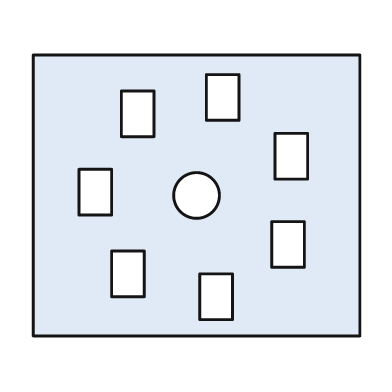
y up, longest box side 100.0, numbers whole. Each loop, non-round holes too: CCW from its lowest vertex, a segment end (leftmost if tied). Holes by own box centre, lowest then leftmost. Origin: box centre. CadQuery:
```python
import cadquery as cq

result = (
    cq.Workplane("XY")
    .moveTo(-50.0, -43.0)
    .lineTo(50.0, -43.0)
    .lineTo(50.0, 43.0)
    .lineTo(-50.0, 43.0)
    .close()
    .moveTo(1.0, -38.0)
    .lineTo(11.0, -38.0)
    .lineTo(11.0, -24.0)
    .lineTo(1.0, -24.0)
    .close()
    .moveTo(-26.0, -31.0)
    .lineTo(-16.0, -31.0)
    .lineTo(-16.0, -17.0)
    .lineTo(-26.0, -17.0)
    .close()
    .moveTo(23.0, -22.0)
    .lineTo(33.0, -22.0)
    .lineTo(33.0, -8.0)
    .lineTo(23.0, -8.0)
    .close()
    .moveTo(0.0, 0.0)
    .circle(7.0)
    .moveTo(-36.0, -6.0)
    .lineTo(-26.0, -6.0)
    .lineTo(-26.0, 8.0)
    .lineTo(-36.0, 8.0)
    .close()
    .moveTo(24.0, 5.0)
    .lineTo(34.0, 5.0)
    .lineTo(34.0, 19.0)
    .lineTo(24.0, 19.0)
    .close()
    .moveTo(-23.0, 18.0)
    .lineTo(-13.0, 18.0)
    .lineTo(-13.0, 32.0)
    .lineTo(-23.0, 32.0)
    .close()
    .moveTo(3.0, 23.0)
    .lineTo(13.0, 23.0)
    .lineTo(13.0, 37.0)
    .lineTo(3.0, 37.0)
    .close()
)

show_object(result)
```